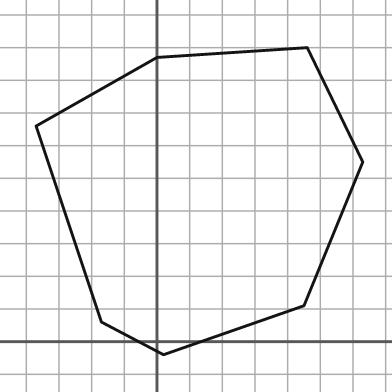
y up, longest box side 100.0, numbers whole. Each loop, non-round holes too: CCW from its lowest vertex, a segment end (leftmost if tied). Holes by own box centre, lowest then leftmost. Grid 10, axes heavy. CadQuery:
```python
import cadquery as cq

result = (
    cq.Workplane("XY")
    .moveTo(2.0, -4.0)
    .lineTo(45.0, 11.0)
    .lineTo(63.0, 55.0)
    .lineTo(46.0, 90.0)
    .lineTo(0.0, 87.0)
    .lineTo(-37.0, 66.0)
    .lineTo(-17.0, 6.0)
    .close()
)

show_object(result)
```